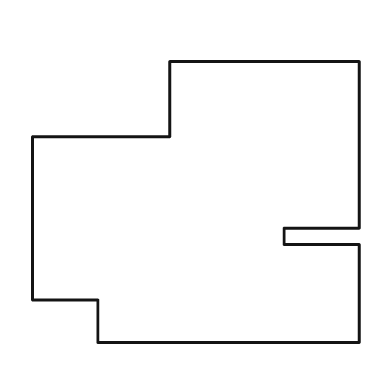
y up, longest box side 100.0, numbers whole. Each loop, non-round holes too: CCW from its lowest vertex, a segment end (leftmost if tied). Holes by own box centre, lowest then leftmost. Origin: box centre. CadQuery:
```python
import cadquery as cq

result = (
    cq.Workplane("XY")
    .moveTo(-30.0, -43.0)
    .lineTo(50.0, -43.0)
    .lineTo(50.0, -13.0)
    .lineTo(27.0, -13.0)
    .lineTo(27.0, -8.0)
    .lineTo(50.0, -8.0)
    .lineTo(50.0, 43.0)
    .lineTo(-8.0, 43.0)
    .lineTo(-8.0, 20.0)
    .lineTo(-50.0, 20.0)
    .lineTo(-50.0, -30.0)
    .lineTo(-30.0, -30.0)
    .close()
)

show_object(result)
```